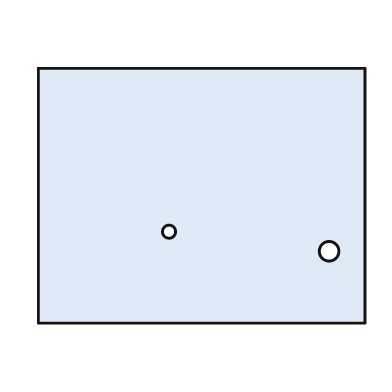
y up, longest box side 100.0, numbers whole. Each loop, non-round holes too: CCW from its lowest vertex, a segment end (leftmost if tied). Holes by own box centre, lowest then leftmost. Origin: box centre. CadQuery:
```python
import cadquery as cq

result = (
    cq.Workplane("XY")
    .moveTo(-50.0, -39.0)
    .lineTo(50.0, -39.0)
    .lineTo(50.0, 39.0)
    .lineTo(-50.0, 39.0)
    .close()
    .moveTo(39.0, -17.0)
    .circle(3.0)
    .moveTo(-10.0, -11.0)
    .circle(2.0)
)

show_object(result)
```